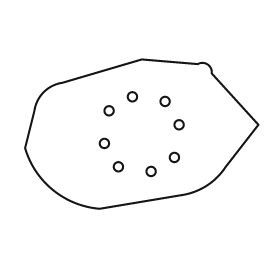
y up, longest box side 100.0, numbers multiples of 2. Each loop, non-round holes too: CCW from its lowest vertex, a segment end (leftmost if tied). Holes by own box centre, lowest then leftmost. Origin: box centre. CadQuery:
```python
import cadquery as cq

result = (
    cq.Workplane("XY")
    .moveTo(-18.0, -32.0)
    .lineTo(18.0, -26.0)
    .threePointArc((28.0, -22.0), (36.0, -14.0))
    .lineTo(50.0, 4.0)
    .lineTo(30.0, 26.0)
    .threePointArc((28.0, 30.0), (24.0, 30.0))
    .lineTo(0.0, 32.0)
    .lineTo(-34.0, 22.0)
    .threePointArc((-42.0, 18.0), (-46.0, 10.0))
    .lineTo(-50.0, -6.0)
    .threePointArc((-38.0, -24.0), (-18.0, -32.0))
    .close()
    .moveTo(4.0, -16.0)
    .circle(2.0)
    .moveTo(-10.0, -14.0)
    .circle(2.0)
    .moveTo(14.0, -10.0)
    .circle(2.0)
    .moveTo(-16.0, -4.0)
    .circle(2.0)
    .moveTo(16.0, 4.0)
    .circle(2.0)
    .moveTo(-14.0, 10.0)
    .circle(2.0)
    .moveTo(10.0, 14.0)
    .circle(2.0)
    .moveTo(-4.0, 16.0)
    .circle(2.0)
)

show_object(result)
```